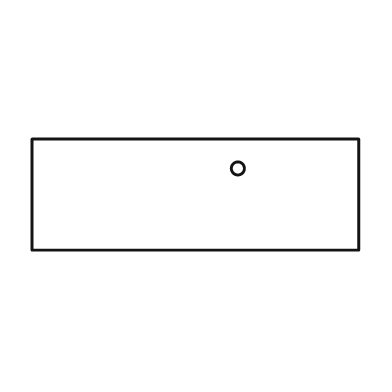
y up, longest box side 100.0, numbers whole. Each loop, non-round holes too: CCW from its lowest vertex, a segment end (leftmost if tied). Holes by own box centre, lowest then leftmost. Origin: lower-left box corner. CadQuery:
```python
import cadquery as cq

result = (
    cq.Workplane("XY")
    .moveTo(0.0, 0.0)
    .lineTo(100.0, 0.0)
    .lineTo(100.0, 34.0)
    .lineTo(0.0, 34.0)
    .close()
    .moveTo(63.0, 25.0)
    .circle(2.0)
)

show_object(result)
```